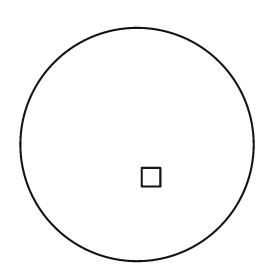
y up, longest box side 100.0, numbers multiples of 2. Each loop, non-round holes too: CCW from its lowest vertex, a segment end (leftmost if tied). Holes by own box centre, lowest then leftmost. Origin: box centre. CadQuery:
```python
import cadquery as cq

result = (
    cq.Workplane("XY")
    .moveTo(0.0, 0.0)
    .circle(50.0)
    .moveTo(2.0, -18.0)
    .lineTo(10.0, -18.0)
    .lineTo(10.0, -10.0)
    .lineTo(2.0, -10.0)
    .close()
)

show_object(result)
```